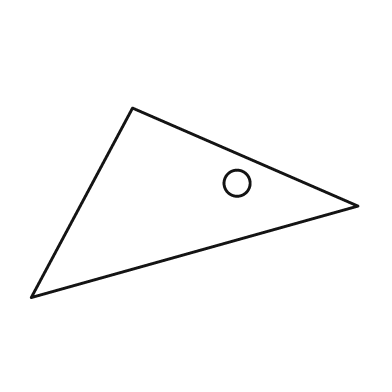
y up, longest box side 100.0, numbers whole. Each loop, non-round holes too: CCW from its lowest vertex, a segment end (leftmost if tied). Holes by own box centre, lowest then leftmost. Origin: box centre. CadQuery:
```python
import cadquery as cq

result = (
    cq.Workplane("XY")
    .moveTo(-50.0, -29.0)
    .lineTo(50.0, -1.0)
    .lineTo(-19.0, 29.0)
    .close()
    .moveTo(13.0, 6.0)
    .circle(4.0)
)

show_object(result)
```